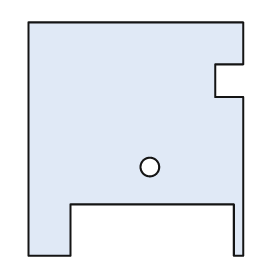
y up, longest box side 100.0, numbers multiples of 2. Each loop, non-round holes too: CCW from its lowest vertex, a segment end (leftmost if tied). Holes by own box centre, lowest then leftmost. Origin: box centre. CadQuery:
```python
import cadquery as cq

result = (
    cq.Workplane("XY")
    .moveTo(-46.0, -50.0)
    .lineTo(-28.0, -50.0)
    .lineTo(-28.0, -28.0)
    .lineTo(42.0, -28.0)
    .lineTo(42.0, -50.0)
    .lineTo(46.0, -50.0)
    .lineTo(46.0, 18.0)
    .lineTo(34.0, 18.0)
    .lineTo(34.0, 32.0)
    .lineTo(46.0, 32.0)
    .lineTo(46.0, 50.0)
    .lineTo(-46.0, 50.0)
    .close()
    .moveTo(6.0, -12.0)
    .circle(4.0)
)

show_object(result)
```